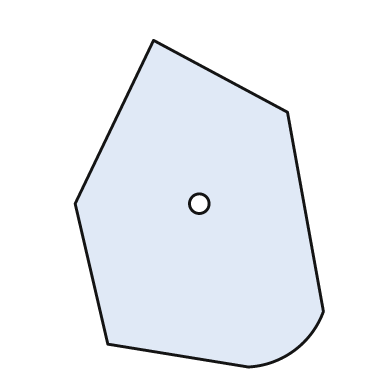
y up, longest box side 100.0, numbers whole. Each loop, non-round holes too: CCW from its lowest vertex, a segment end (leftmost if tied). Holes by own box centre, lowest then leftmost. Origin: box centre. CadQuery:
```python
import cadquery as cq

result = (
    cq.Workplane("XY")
    .moveTo(15.0, -50.0)
    .threePointArc((29.0, -45.0), (38.0, -33.0))
    .lineTo(27.0, 28.0)
    .lineTo(-14.0, 50.0)
    .lineTo(-38.0, 0.0)
    .lineTo(-28.0, -43.0)
    .close()
    .moveTo(0.0, 0.0)
    .circle(3.0)
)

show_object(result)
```